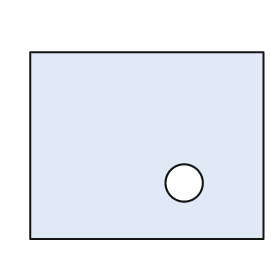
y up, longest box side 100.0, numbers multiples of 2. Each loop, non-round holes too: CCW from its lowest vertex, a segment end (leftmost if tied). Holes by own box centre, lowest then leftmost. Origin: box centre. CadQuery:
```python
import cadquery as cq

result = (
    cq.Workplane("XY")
    .moveTo(-50.0, -40.0)
    .lineTo(50.0, -40.0)
    .lineTo(50.0, 40.0)
    .lineTo(-50.0, 40.0)
    .close()
    .moveTo(16.0, -16.0)
    .circle(8.0)
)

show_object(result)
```